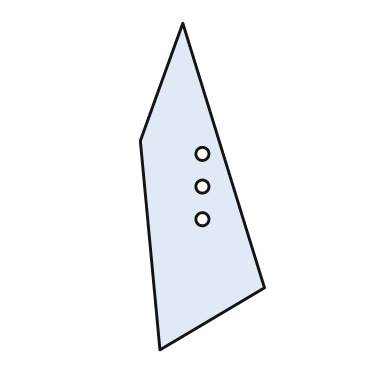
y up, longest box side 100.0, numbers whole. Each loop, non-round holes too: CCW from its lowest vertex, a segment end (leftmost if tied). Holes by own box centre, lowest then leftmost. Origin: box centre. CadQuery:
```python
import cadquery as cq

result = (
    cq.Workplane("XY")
    .moveTo(-13.0, -50.0)
    .lineTo(19.0, -31.0)
    .lineTo(-6.0, 50.0)
    .lineTo(-19.0, 14.0)
    .close()
    .moveTo(0.0, -10.0)
    .circle(2.0)
    .moveTo(0.0, 0.0)
    .circle(2.0)
    .moveTo(0.0, 10.0)
    .circle(2.0)
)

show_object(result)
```